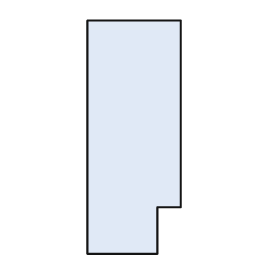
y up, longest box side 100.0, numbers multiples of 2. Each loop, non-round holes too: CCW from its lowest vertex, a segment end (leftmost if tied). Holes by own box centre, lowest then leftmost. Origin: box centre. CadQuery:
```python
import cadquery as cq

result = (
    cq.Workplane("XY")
    .moveTo(-20.0, -50.0)
    .lineTo(10.0, -50.0)
    .lineTo(10.0, -30.0)
    .lineTo(20.0, -30.0)
    .lineTo(20.0, 50.0)
    .lineTo(-20.0, 50.0)
    .close()
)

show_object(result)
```